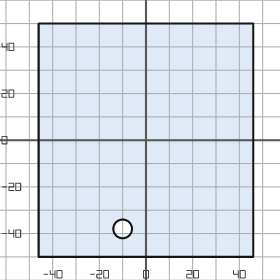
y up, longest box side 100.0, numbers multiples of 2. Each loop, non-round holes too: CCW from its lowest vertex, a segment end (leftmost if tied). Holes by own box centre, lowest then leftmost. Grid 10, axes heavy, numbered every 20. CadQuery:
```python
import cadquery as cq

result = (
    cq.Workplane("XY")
    .moveTo(-46.0, -50.0)
    .lineTo(46.0, -50.0)
    .lineTo(46.0, 50.0)
    .lineTo(-46.0, 50.0)
    .close()
    .moveTo(-10.0, -38.0)
    .circle(4.0)
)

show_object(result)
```